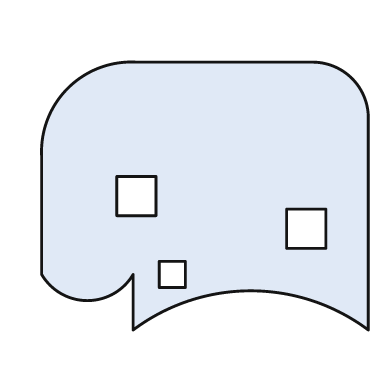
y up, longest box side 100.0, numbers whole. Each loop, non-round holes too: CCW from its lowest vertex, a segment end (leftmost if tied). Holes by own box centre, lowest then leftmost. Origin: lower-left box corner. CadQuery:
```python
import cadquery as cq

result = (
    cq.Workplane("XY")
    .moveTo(28.0, 0.0)
    .threePointArc((64.0, 12.0), (100.0, 0.0))
    .lineTo(100.0, 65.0)
    .threePointArc((95.0, 77.0), (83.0, 82.0))
    .lineTo(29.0, 82.0)
    .threePointArc((8.0, 74.0), (0.0, 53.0))
    .lineTo(0.0, 17.0)
    .threePointArc((14.0, 9.0), (28.0, 17.0))
    .close()
    .moveTo(36.0, 13.0)
    .lineTo(44.0, 13.0)
    .lineTo(44.0, 21.0)
    .lineTo(36.0, 21.0)
    .close()
    .moveTo(75.0, 25.0)
    .lineTo(87.0, 25.0)
    .lineTo(87.0, 37.0)
    .lineTo(75.0, 37.0)
    .close()
    .moveTo(23.0, 35.0)
    .lineTo(35.0, 35.0)
    .lineTo(35.0, 47.0)
    .lineTo(23.0, 47.0)
    .close()
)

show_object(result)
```